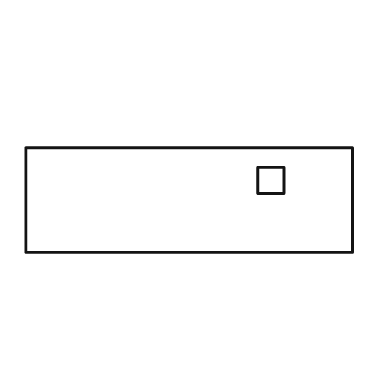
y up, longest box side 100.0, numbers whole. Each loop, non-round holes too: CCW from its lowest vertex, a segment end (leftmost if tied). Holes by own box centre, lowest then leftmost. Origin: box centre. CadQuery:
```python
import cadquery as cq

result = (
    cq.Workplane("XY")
    .moveTo(-50.0, -16.0)
    .lineTo(50.0, -16.0)
    .lineTo(50.0, 16.0)
    .lineTo(-50.0, 16.0)
    .close()
    .moveTo(21.0, 2.0)
    .lineTo(29.0, 2.0)
    .lineTo(29.0, 10.0)
    .lineTo(21.0, 10.0)
    .close()
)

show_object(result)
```